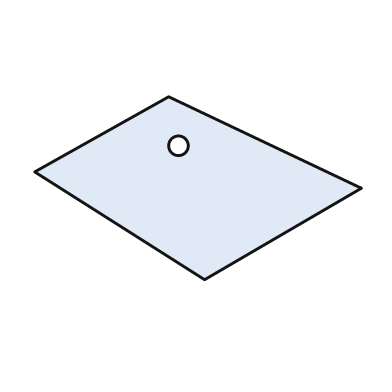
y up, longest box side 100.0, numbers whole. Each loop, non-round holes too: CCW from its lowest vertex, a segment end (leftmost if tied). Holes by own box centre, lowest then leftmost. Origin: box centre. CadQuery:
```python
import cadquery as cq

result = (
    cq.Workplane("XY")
    .moveTo(2.0, -28.0)
    .lineTo(50.0, 0.0)
    .lineTo(-9.0, 28.0)
    .lineTo(-50.0, 5.0)
    .close()
    .moveTo(-6.0, 13.0)
    .circle(3.0)
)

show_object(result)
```